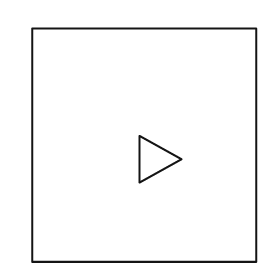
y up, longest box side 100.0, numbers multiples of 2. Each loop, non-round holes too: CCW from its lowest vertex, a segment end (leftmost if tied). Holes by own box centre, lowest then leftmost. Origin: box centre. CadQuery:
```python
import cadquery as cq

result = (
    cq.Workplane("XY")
    .moveTo(-48.0, -50.0)
    .lineTo(48.0, -50.0)
    .lineTo(48.0, 50.0)
    .lineTo(-48.0, 50.0)
    .close()
    .moveTo(-2.0, -16.0)
    .lineTo(16.0, -6.0)
    .lineTo(-2.0, 4.0)
    .close()
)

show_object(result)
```